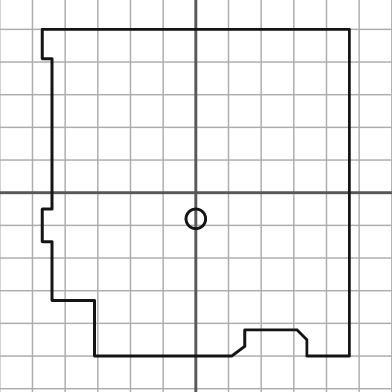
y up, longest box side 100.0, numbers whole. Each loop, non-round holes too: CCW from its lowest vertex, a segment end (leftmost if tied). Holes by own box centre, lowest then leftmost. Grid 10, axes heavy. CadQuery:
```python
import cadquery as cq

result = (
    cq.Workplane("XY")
    .moveTo(-31.0, -50.0)
    .lineTo(11.0, -50.0)
    .lineTo(15.0, -47.0)
    .lineTo(15.0, -42.0)
    .lineTo(31.0, -42.0)
    .lineTo(34.0, -45.0)
    .lineTo(34.0, -50.0)
    .lineTo(47.0, -50.0)
    .lineTo(47.0, 50.0)
    .lineTo(-47.0, 50.0)
    .lineTo(-47.0, 41.0)
    .lineTo(-44.0, 41.0)
    .lineTo(-44.0, -5.0)
    .lineTo(-47.0, -5.0)
    .lineTo(-47.0, -15.0)
    .lineTo(-44.0, -15.0)
    .lineTo(-44.0, -33.0)
    .lineTo(-31.0, -33.0)
    .close()
    .moveTo(0.0, -8.0)
    .circle(3.0)
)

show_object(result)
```